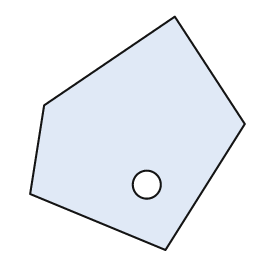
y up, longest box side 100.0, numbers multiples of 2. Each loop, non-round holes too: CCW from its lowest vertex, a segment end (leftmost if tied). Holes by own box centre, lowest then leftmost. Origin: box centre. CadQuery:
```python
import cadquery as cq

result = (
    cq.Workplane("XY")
    .moveTo(12.0, -50.0)
    .lineTo(46.0, 4.0)
    .lineTo(16.0, 50.0)
    .lineTo(-40.0, 12.0)
    .lineTo(-46.0, -26.0)
    .close()
    .moveTo(4.0, -22.0)
    .circle(6.0)
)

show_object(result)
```